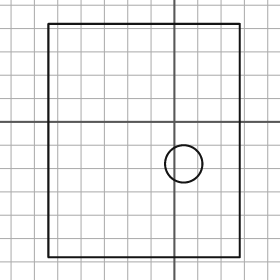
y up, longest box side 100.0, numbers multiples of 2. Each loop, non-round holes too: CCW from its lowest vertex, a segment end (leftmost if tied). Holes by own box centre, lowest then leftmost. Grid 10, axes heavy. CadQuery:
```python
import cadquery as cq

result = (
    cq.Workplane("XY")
    .moveTo(-54.0, -58.0)
    .lineTo(28.0, -58.0)
    .lineTo(28.0, 42.0)
    .lineTo(-54.0, 42.0)
    .close()
    .moveTo(4.0, -18.0)
    .circle(8.0)
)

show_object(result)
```